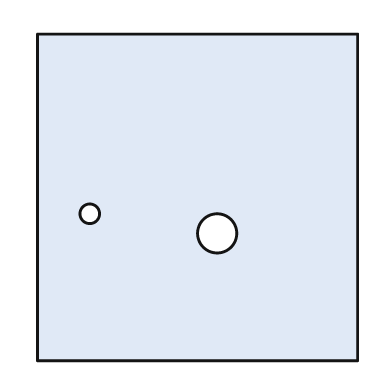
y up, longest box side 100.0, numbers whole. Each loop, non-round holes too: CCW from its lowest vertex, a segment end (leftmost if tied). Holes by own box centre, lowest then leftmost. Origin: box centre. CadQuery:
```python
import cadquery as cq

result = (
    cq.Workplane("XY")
    .moveTo(-49.0, -50.0)
    .lineTo(49.0, -50.0)
    .lineTo(49.0, 50.0)
    .lineTo(-49.0, 50.0)
    .close()
    .moveTo(6.0, -11.0)
    .circle(6.0)
    .moveTo(-33.0, -5.0)
    .circle(3.0)
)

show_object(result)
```